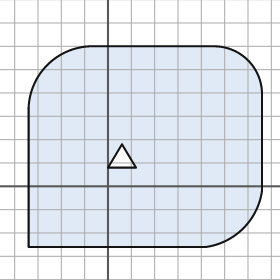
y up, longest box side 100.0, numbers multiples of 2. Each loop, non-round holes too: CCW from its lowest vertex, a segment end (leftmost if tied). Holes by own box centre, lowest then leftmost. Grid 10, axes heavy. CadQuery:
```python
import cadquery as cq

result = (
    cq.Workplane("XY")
    .moveTo(-34.0, -26.0)
    .lineTo(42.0, -26.0)
    .threePointArc((58.0, -18.0), (66.0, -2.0))
    .lineTo(66.0, 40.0)
    .threePointArc((60.0, 54.0), (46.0, 60.0))
    .lineTo(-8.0, 60.0)
    .threePointArc((-26.0, 52.0), (-34.0, 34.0))
    .close()
    .moveTo(0.0, 8.0)
    .lineTo(12.0, 8.0)
    .lineTo(6.0, 18.0)
    .close()
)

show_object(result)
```